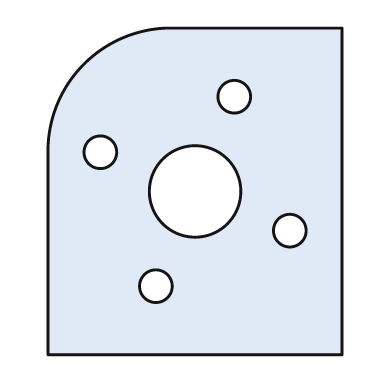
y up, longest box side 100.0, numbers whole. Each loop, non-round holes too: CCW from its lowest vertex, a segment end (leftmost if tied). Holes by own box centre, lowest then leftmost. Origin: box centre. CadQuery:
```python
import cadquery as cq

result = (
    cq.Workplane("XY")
    .moveTo(-45.0, -50.0)
    .lineTo(45.0, -50.0)
    .lineTo(45.0, 50.0)
    .lineTo(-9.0, 50.0)
    .threePointArc((-34.0, 39.0), (-45.0, 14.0))
    .close()
    .moveTo(-12.0, -29.0)
    .circle(5.0)
    .moveTo(29.0, -12.0)
    .circle(5.0)
    .moveTo(0.0, 0.0)
    .circle(14.0)
    .moveTo(-29.0, 12.0)
    .circle(5.0)
    .moveTo(12.0, 29.0)
    .circle(5.0)
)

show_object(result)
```